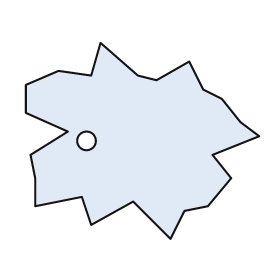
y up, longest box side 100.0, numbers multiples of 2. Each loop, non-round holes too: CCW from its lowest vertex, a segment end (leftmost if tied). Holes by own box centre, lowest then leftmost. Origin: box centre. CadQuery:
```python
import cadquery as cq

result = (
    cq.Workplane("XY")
    .moveTo(12.0, -42.0)
    .lineTo(18.0, -30.0)
    .lineTo(28.0, -28.0)
    .lineTo(38.0, -16.0)
    .lineTo(30.0, -6.0)
    .lineTo(50.0, 2.0)
    .lineTo(42.0, 8.0)
    .lineTo(34.0, 18.0)
    .lineTo(26.0, 22.0)
    .lineTo(20.0, 34.0)
    .lineTo(6.0, 26.0)
    .lineTo(-2.0, 28.0)
    .lineTo(-18.0, 42.0)
    .lineTo(-22.0, 28.0)
    .lineTo(-36.0, 30.0)
    .lineTo(-50.0, 24.0)
    .lineTo(-50.0, 12.0)
    .lineTo(-32.0, 4.0)
    .lineTo(-48.0, -6.0)
    .lineTo(-46.0, -16.0)
    .lineTo(-46.0, -28.0)
    .lineTo(-26.0, -24.0)
    .lineTo(-22.0, -36.0)
    .lineTo(-4.0, -26.0)
    .close()
    .moveTo(-24.0, 0.0)
    .circle(4.0)
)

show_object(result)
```